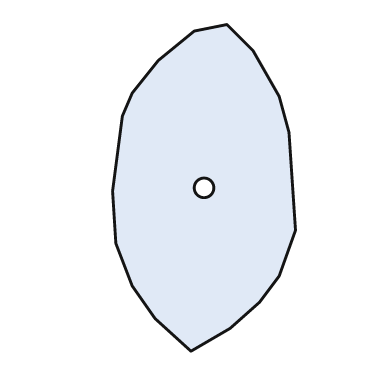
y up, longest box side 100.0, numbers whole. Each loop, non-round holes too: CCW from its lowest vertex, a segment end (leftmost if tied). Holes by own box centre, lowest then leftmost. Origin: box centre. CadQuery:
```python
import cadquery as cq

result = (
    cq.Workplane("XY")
    .moveTo(-4.0, -50.0)
    .lineTo(8.0, -43.0)
    .lineTo(17.0, -35.0)
    .lineTo(23.0, -27.0)
    .lineTo(28.0, -13.0)
    .lineTo(26.0, 17.0)
    .lineTo(23.0, 28.0)
    .lineTo(15.0, 42.0)
    .lineTo(7.0, 50.0)
    .lineTo(-3.0, 48.0)
    .lineTo(-14.0, 39.0)
    .lineTo(-22.0, 29.0)
    .lineTo(-25.0, 22.0)
    .lineTo(-28.0, -1.0)
    .lineTo(-27.0, -17.0)
    .lineTo(-22.0, -30.0)
    .lineTo(-15.0, -40.0)
    .close()
    .moveTo(0.0, 0.0)
    .circle(3.0)
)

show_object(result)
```